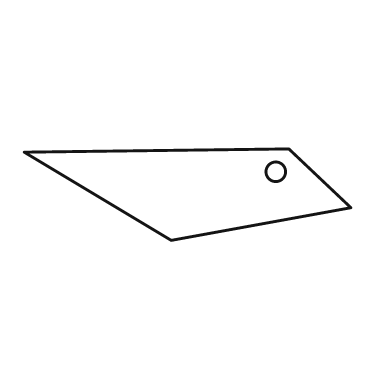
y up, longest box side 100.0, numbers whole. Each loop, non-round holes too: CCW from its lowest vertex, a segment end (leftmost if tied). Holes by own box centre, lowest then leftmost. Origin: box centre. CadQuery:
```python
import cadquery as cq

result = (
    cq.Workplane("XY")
    .moveTo(-5.0, -14.0)
    .lineTo(50.0, -4.0)
    .lineTo(31.0, 14.0)
    .lineTo(-50.0, 13.0)
    .close()
    .moveTo(27.0, 7.0)
    .circle(3.0)
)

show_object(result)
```